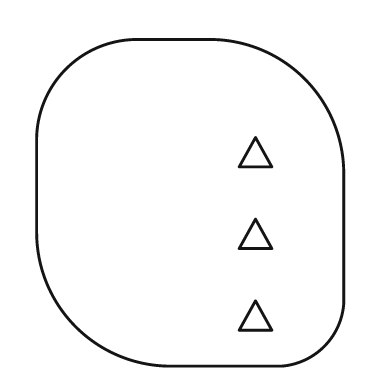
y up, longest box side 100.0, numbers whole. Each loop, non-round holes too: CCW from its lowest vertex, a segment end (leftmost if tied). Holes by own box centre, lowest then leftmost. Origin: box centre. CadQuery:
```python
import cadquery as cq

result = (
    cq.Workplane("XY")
    .moveTo(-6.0, -50.0)
    .lineTo(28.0, -50.0)
    .threePointArc((41.0, -44.0), (47.0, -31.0))
    .lineTo(47.0, 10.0)
    .threePointArc((35.0, 38.0), (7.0, 50.0))
    .lineTo(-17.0, 50.0)
    .threePointArc((-38.0, 41.0), (-47.0, 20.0))
    .lineTo(-47.0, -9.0)
    .threePointArc((-35.0, -38.0), (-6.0, -50.0))
    .close()
    .moveTo(15.0, -39.0)
    .lineTo(25.0, -39.0)
    .lineTo(20.0, -30.0)
    .close()
    .moveTo(15.0, -14.0)
    .lineTo(25.0, -14.0)
    .lineTo(20.0, -5.0)
    .close()
    .moveTo(15.0, 11.0)
    .lineTo(25.0, 11.0)
    .lineTo(20.0, 20.0)
    .close()
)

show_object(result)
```